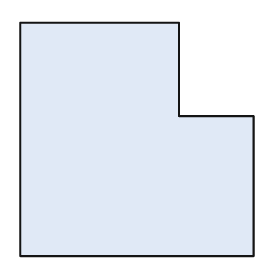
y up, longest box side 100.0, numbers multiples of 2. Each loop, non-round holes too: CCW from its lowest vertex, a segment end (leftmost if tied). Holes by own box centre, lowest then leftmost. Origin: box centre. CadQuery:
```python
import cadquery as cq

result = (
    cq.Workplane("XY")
    .moveTo(-50.0, -50.0)
    .lineTo(50.0, -50.0)
    .lineTo(50.0, 10.0)
    .lineTo(18.0, 10.0)
    .lineTo(18.0, 50.0)
    .lineTo(-50.0, 50.0)
    .close()
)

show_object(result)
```